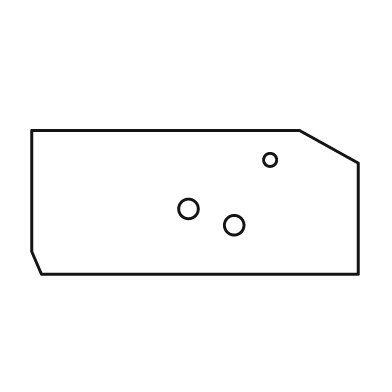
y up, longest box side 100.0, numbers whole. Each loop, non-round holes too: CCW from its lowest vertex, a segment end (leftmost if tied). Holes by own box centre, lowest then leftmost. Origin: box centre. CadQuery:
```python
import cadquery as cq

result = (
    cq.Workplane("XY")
    .moveTo(-47.0, -22.0)
    .lineTo(50.0, -22.0)
    .lineTo(50.0, 12.0)
    .lineTo(32.0, 22.0)
    .lineTo(-50.0, 22.0)
    .lineTo(-50.0, -15.0)
    .close()
    .moveTo(12.0, -7.0)
    .circle(3.0)
    .moveTo(-2.0, -2.0)
    .circle(3.0)
    .moveTo(23.0, 13.0)
    .circle(2.0)
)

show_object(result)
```